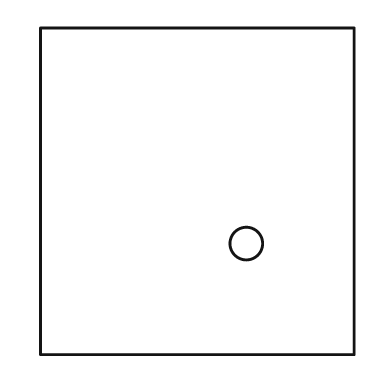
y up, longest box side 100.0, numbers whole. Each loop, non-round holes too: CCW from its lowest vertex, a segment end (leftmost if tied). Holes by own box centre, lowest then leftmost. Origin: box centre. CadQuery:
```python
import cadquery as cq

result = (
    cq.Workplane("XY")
    .moveTo(-48.0, -50.0)
    .lineTo(48.0, -50.0)
    .lineTo(48.0, 50.0)
    .lineTo(-48.0, 50.0)
    .close()
    .moveTo(15.0, -16.0)
    .circle(5.0)
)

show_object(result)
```